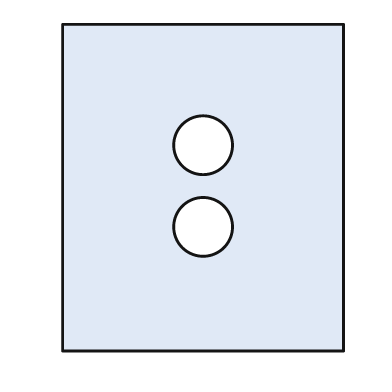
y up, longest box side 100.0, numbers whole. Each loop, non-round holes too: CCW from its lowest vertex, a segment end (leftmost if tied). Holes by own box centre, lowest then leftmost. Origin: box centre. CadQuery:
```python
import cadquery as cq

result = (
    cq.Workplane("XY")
    .moveTo(-43.0, -50.0)
    .lineTo(43.0, -50.0)
    .lineTo(43.0, 50.0)
    .lineTo(-43.0, 50.0)
    .close()
    .moveTo(0.0, -12.0)
    .circle(9.0)
    .moveTo(0.0, 13.0)
    .circle(9.0)
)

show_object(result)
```